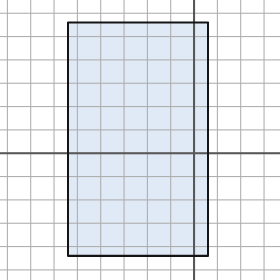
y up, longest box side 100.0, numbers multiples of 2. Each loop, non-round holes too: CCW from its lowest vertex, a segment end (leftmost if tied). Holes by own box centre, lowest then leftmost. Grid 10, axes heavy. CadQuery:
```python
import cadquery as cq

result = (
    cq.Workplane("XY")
    .moveTo(-54.0, -44.0)
    .lineTo(6.0, -44.0)
    .lineTo(6.0, 56.0)
    .lineTo(-54.0, 56.0)
    .close()
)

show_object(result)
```